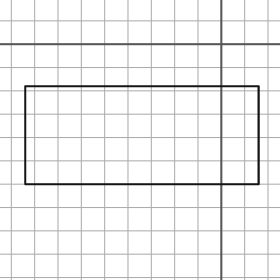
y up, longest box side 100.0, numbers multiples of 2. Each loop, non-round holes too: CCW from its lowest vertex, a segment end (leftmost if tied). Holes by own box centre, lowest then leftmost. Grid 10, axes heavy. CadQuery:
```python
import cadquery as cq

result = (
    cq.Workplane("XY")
    .moveTo(-84.0, -60.0)
    .lineTo(16.0, -60.0)
    .lineTo(16.0, -18.0)
    .lineTo(-84.0, -18.0)
    .close()
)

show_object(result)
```